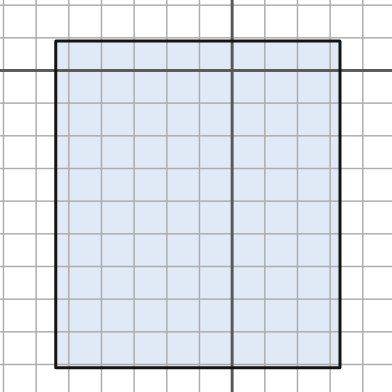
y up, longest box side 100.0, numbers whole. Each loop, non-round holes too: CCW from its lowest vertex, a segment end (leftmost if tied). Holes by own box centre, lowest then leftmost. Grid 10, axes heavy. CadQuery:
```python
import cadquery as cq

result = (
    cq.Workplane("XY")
    .moveTo(-54.0, -91.0)
    .lineTo(33.0, -91.0)
    .lineTo(33.0, 9.0)
    .lineTo(-54.0, 9.0)
    .close()
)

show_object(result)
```